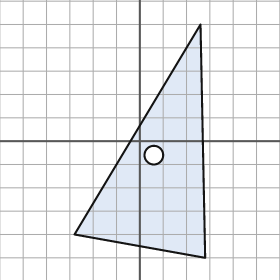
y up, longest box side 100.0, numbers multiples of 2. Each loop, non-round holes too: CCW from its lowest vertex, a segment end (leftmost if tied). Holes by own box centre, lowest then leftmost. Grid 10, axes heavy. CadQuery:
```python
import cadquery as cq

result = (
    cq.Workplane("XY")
    .moveTo(28.0, -50.0)
    .lineTo(26.0, 50.0)
    .lineTo(-28.0, -40.0)
    .close()
    .moveTo(6.0, -6.0)
    .circle(4.0)
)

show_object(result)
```